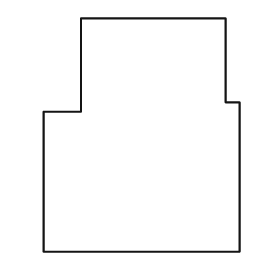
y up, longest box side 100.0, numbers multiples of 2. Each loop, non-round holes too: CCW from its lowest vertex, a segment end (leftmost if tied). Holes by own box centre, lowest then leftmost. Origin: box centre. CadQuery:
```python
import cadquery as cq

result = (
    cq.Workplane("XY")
    .moveTo(-42.0, -50.0)
    .lineTo(42.0, -50.0)
    .lineTo(42.0, 14.0)
    .lineTo(36.0, 14.0)
    .lineTo(36.0, 50.0)
    .lineTo(-26.0, 50.0)
    .lineTo(-26.0, 10.0)
    .lineTo(-42.0, 10.0)
    .close()
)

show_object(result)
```